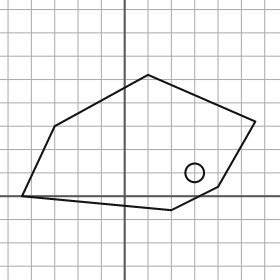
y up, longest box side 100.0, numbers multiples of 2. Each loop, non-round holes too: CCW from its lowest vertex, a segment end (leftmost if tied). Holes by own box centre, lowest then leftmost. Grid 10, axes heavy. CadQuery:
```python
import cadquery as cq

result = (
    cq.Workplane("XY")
    .moveTo(20.0, -6.0)
    .lineTo(40.0, 4.0)
    .lineTo(56.0, 32.0)
    .lineTo(10.0, 52.0)
    .lineTo(-30.0, 30.0)
    .lineTo(-44.0, 0.0)
    .close()
    .moveTo(30.0, 10.0)
    .circle(4.0)
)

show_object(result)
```